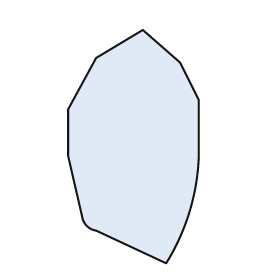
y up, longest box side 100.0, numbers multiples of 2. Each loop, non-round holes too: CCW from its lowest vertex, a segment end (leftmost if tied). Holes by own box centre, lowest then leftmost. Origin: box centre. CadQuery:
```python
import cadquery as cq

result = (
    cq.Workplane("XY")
    .moveTo(14.0, -50.0)
    .threePointArc((24.0, -28.0), (28.0, -4.0))
    .lineTo(28.0, 20.0)
    .lineTo(20.0, 36.0)
    .lineTo(4.0, 50.0)
    .lineTo(-16.0, 38.0)
    .lineTo(-28.0, 16.0)
    .lineTo(-28.0, -4.0)
    .lineTo(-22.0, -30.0)
    .threePointArc((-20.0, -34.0), (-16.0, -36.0))
    .close()
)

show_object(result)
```